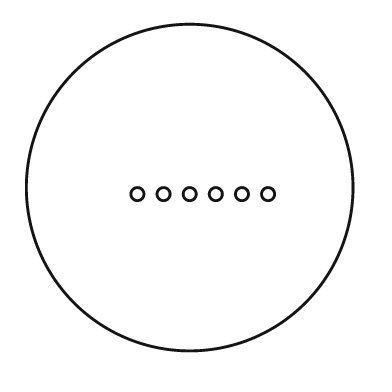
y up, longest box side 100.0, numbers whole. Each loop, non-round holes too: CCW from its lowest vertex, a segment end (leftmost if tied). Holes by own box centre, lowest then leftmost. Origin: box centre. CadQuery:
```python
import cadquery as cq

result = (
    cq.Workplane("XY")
    .moveTo(0.0, 0.0)
    .circle(50.0)
    .moveTo(-16.0, -2.0)
    .circle(2.0)
    .moveTo(-8.0, -2.0)
    .circle(2.0)
    .moveTo(0.0, -2.0)
    .circle(2.0)
    .moveTo(8.0, -2.0)
    .circle(2.0)
    .moveTo(16.0, -2.0)
    .circle(2.0)
    .moveTo(24.0, -2.0)
    .circle(2.0)
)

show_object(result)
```